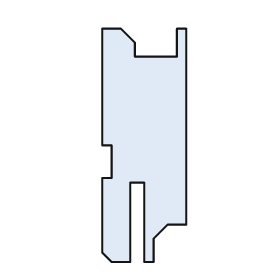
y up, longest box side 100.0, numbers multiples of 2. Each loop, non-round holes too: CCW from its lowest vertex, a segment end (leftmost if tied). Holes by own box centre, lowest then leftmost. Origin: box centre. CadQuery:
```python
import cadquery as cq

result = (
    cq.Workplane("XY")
    .moveTo(-14.0, -50.0)
    .lineTo(-6.0, -50.0)
    .lineTo(-6.0, -16.0)
    .lineTo(0.0, -16.0)
    .lineTo(0.0, -50.0)
    .lineTo(4.0, -50.0)
    .lineTo(4.0, -40.0)
    .lineTo(10.0, -34.0)
    .lineTo(18.0, -34.0)
    .lineTo(18.0, 50.0)
    .lineTo(14.0, 50.0)
    .lineTo(14.0, 38.0)
    .lineTo(-4.0, 38.0)
    .lineTo(-4.0, 44.0)
    .lineTo(-10.0, 50.0)
    .lineTo(-18.0, 50.0)
    .lineTo(-18.0, 0.0)
    .lineTo(-14.0, 0.0)
    .lineTo(-14.0, -14.0)
    .lineTo(-18.0, -14.0)
    .lineTo(-18.0, -46.0)
    .close()
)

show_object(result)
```